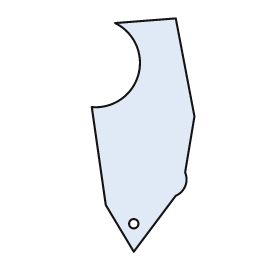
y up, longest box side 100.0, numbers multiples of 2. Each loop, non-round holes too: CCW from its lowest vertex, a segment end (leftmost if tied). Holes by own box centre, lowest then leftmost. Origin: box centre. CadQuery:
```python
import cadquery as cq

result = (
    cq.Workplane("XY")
    .moveTo(-4.0, -50.0)
    .lineTo(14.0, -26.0)
    .threePointArc((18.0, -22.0), (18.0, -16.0))
    .lineTo(22.0, 8.0)
    .lineTo(14.0, 50.0)
    .lineTo(-12.0, 48.0)
    .threePointArc((-2.0, 26.0), (-22.0, 12.0))
    .lineTo(-16.0, -30.0)
    .close()
    .moveTo(-4.0, -38.0)
    .circle(2.0)
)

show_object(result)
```